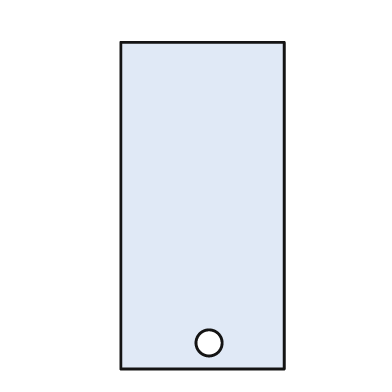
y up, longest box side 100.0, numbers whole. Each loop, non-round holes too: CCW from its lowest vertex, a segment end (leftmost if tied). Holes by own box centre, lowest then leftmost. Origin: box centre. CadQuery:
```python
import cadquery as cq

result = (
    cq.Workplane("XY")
    .moveTo(-25.0, -50.0)
    .lineTo(25.0, -50.0)
    .lineTo(25.0, 50.0)
    .lineTo(-25.0, 50.0)
    .close()
    .moveTo(2.0, -42.0)
    .circle(4.0)
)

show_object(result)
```